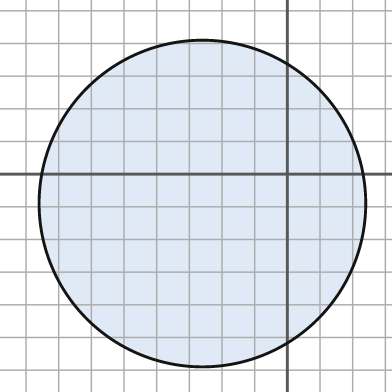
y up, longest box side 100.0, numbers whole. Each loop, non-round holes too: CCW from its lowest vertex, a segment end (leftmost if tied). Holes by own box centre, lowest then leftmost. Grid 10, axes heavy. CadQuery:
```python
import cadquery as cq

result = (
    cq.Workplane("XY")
    .moveTo(-26.0, -9.0)
    .circle(50.0)
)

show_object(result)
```